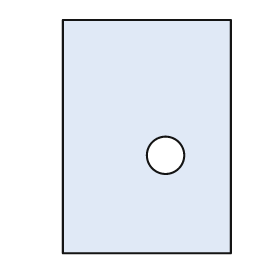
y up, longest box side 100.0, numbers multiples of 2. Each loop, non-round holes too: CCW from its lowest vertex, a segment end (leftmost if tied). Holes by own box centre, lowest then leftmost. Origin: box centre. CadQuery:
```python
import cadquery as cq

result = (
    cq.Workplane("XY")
    .moveTo(-36.0, -50.0)
    .lineTo(36.0, -50.0)
    .lineTo(36.0, 50.0)
    .lineTo(-36.0, 50.0)
    .close()
    .moveTo(8.0, -8.0)
    .circle(8.0)
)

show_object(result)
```